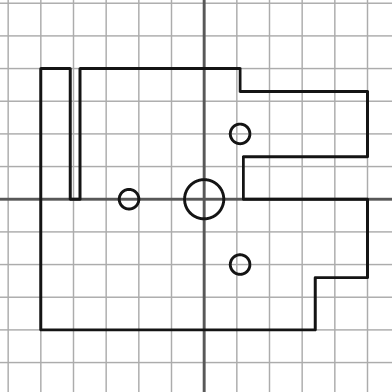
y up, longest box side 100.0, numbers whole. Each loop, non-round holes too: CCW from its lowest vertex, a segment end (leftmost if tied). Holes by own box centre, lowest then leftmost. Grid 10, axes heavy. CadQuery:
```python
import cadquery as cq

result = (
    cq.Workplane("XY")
    .moveTo(-50.0, -40.0)
    .lineTo(34.0, -40.0)
    .lineTo(34.0, -24.0)
    .lineTo(50.0, -24.0)
    .lineTo(50.0, 0.0)
    .lineTo(12.0, 0.0)
    .lineTo(12.0, 13.0)
    .lineTo(50.0, 13.0)
    .lineTo(50.0, 33.0)
    .lineTo(11.0, 33.0)
    .lineTo(11.0, 40.0)
    .lineTo(-38.0, 40.0)
    .lineTo(-38.0, 0.0)
    .lineTo(-41.0, 0.0)
    .lineTo(-41.0, 40.0)
    .lineTo(-50.0, 40.0)
    .close()
    .moveTo(11.0, -20.0)
    .circle(3.0)
    .moveTo(-23.0, 0.0)
    .circle(3.0)
    .moveTo(0.0, 0.0)
    .circle(6.0)
    .moveTo(11.0, 20.0)
    .circle(3.0)
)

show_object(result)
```